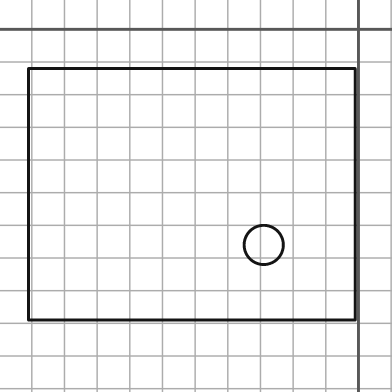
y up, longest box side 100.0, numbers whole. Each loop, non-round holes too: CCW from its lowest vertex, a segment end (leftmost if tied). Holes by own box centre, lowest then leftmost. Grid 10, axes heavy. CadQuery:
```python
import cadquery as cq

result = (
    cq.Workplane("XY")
    .moveTo(-101.0, -89.0)
    .lineTo(-1.0, -89.0)
    .lineTo(-1.0, -12.0)
    .lineTo(-101.0, -12.0)
    .close()
    .moveTo(-29.0, -66.0)
    .circle(6.0)
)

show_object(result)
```